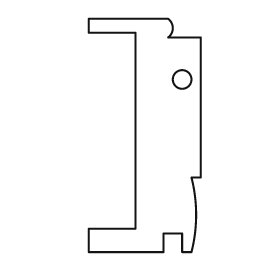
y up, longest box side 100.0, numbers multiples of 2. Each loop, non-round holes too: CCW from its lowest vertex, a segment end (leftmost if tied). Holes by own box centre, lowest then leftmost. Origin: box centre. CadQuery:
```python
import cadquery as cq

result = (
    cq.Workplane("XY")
    .moveTo(-24.0, -50.0)
    .lineTo(8.0, -50.0)
    .lineTo(8.0, -42.0)
    .lineTo(16.0, -42.0)
    .lineTo(16.0, -50.0)
    .lineTo(20.0, -50.0)
    .threePointArc((22.0, -34.0), (20.0, -18.0))
    .lineTo(24.0, -18.0)
    .lineTo(24.0, 42.0)
    .lineTo(10.0, 42.0)
    .threePointArc((12.0, 46.0), (10.0, 50.0))
    .lineTo(-24.0, 50.0)
    .lineTo(-24.0, 44.0)
    .lineTo(-4.0, 44.0)
    .lineTo(-4.0, -40.0)
    .lineTo(-24.0, -40.0)
    .close()
    .moveTo(16.0, 24.0)
    .circle(4.0)
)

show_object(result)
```